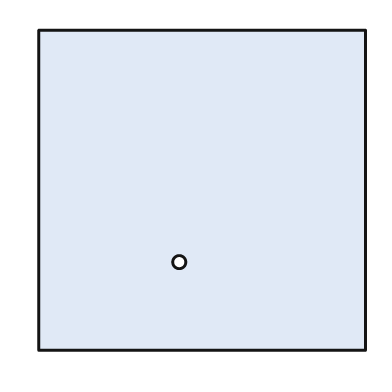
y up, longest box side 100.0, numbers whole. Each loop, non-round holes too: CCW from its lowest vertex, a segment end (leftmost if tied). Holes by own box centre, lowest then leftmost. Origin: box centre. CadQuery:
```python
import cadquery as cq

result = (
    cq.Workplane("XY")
    .moveTo(-50.0, -49.0)
    .lineTo(50.0, -49.0)
    .lineTo(50.0, 49.0)
    .lineTo(-50.0, 49.0)
    .close()
    .moveTo(-7.0, -22.0)
    .circle(2.0)
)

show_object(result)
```